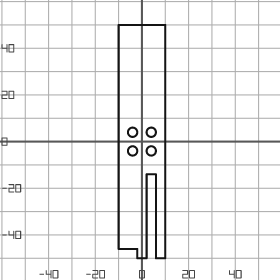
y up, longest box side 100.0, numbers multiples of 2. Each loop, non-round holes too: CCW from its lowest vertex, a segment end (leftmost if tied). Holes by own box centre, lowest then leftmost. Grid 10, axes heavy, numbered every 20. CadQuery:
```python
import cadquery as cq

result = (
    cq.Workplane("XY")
    .moveTo(-2.0, -50.0)
    .lineTo(2.0, -50.0)
    .lineTo(2.0, -14.0)
    .lineTo(6.0, -14.0)
    .lineTo(6.0, -50.0)
    .lineTo(10.0, -50.0)
    .lineTo(10.0, 50.0)
    .lineTo(-10.0, 50.0)
    .lineTo(-10.0, -46.0)
    .lineTo(-2.0, -46.0)
    .close()
    .moveTo(-4.0, -4.0)
    .circle(2.0)
    .moveTo(4.0, -4.0)
    .circle(2.0)
    .moveTo(-4.0, 4.0)
    .circle(2.0)
    .moveTo(4.0, 4.0)
    .circle(2.0)
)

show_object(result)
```